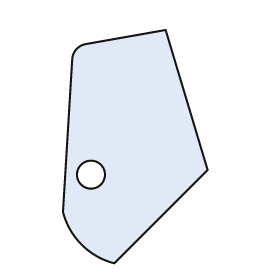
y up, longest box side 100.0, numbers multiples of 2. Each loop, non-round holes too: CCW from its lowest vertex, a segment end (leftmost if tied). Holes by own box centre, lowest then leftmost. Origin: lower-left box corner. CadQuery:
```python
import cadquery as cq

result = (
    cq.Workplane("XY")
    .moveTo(22.0, 0.0)
    .lineTo(62.0, 40.0)
    .lineTo(44.0, 100.0)
    .lineTo(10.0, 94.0)
    .threePointArc((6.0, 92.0), (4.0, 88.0))
    .lineTo(0.0, 22.0)
    .threePointArc((8.0, 8.0), (22.0, 0.0))
    .close()
    .moveTo(12.0, 38.0)
    .circle(6.0)
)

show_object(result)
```